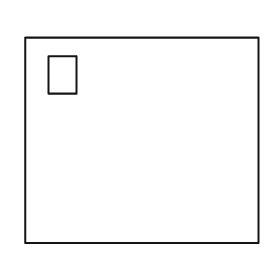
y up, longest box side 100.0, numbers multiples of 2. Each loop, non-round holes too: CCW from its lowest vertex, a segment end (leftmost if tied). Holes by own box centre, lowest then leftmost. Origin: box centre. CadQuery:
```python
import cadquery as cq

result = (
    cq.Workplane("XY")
    .moveTo(-50.0, -44.0)
    .lineTo(50.0, -44.0)
    .lineTo(50.0, 44.0)
    .lineTo(-50.0, 44.0)
    .close()
    .moveTo(-40.0, 20.0)
    .lineTo(-28.0, 20.0)
    .lineTo(-28.0, 36.0)
    .lineTo(-40.0, 36.0)
    .close()
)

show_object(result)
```